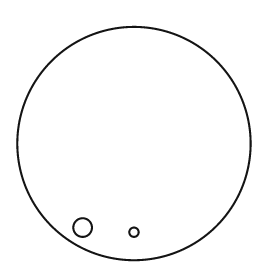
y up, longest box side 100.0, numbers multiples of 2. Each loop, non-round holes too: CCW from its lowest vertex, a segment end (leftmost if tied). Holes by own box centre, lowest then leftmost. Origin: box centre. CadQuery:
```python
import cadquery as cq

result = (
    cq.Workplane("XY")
    .moveTo(0.0, 0.0)
    .circle(50.0)
    .moveTo(0.0, -38.0)
    .circle(2.0)
    .moveTo(-22.0, -36.0)
    .circle(4.0)
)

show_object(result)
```